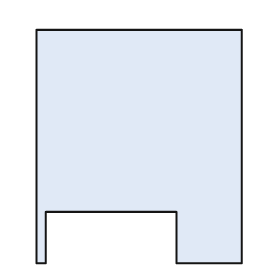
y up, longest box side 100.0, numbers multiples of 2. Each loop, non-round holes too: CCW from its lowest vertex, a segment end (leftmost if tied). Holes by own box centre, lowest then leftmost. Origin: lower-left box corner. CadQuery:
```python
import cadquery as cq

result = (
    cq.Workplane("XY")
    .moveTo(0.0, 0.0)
    .lineTo(4.0, 0.0)
    .lineTo(4.0, 22.0)
    .lineTo(60.0, 22.0)
    .lineTo(60.0, 0.0)
    .lineTo(88.0, 0.0)
    .lineTo(88.0, 100.0)
    .lineTo(0.0, 100.0)
    .close()
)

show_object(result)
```